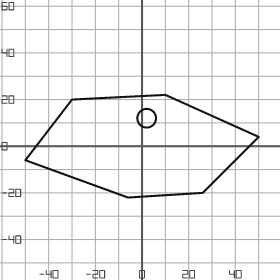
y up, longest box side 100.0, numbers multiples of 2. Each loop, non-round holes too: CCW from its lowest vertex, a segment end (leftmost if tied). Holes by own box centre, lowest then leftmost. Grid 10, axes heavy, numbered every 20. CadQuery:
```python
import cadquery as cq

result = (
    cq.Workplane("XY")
    .moveTo(-6.0, -22.0)
    .lineTo(26.0, -20.0)
    .lineTo(50.0, 4.0)
    .lineTo(10.0, 22.0)
    .lineTo(-30.0, 20.0)
    .lineTo(-50.0, -6.0)
    .close()
    .moveTo(2.0, 12.0)
    .circle(4.0)
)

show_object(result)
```